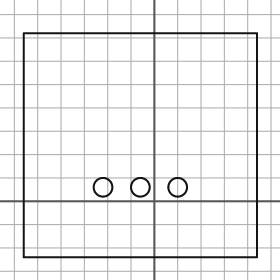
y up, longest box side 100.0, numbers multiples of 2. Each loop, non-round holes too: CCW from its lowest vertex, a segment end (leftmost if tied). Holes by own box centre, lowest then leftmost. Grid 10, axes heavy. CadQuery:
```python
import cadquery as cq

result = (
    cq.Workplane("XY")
    .moveTo(-56.0, -24.0)
    .lineTo(44.0, -24.0)
    .lineTo(44.0, 72.0)
    .lineTo(-56.0, 72.0)
    .close()
    .moveTo(-22.0, 6.0)
    .circle(4.0)
    .moveTo(-6.0, 6.0)
    .circle(4.0)
    .moveTo(10.0, 6.0)
    .circle(4.0)
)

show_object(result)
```